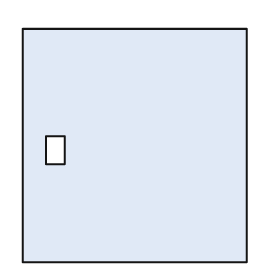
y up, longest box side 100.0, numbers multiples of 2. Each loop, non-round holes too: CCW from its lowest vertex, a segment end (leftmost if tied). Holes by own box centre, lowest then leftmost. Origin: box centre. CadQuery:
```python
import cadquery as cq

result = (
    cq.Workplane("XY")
    .moveTo(-48.0, -50.0)
    .lineTo(48.0, -50.0)
    .lineTo(48.0, 50.0)
    .lineTo(-48.0, 50.0)
    .close()
    .moveTo(-38.0, -8.0)
    .lineTo(-30.0, -8.0)
    .lineTo(-30.0, 4.0)
    .lineTo(-38.0, 4.0)
    .close()
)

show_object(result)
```